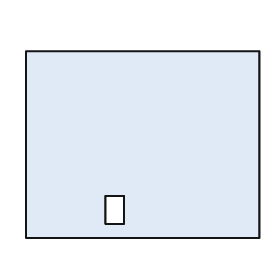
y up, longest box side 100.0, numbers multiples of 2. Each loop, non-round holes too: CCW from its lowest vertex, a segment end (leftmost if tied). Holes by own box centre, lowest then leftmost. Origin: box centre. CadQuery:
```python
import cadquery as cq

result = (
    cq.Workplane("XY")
    .moveTo(-50.0, -40.0)
    .lineTo(50.0, -40.0)
    .lineTo(50.0, 40.0)
    .lineTo(-50.0, 40.0)
    .close()
    .moveTo(-16.0, -34.0)
    .lineTo(-8.0, -34.0)
    .lineTo(-8.0, -22.0)
    .lineTo(-16.0, -22.0)
    .close()
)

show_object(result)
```